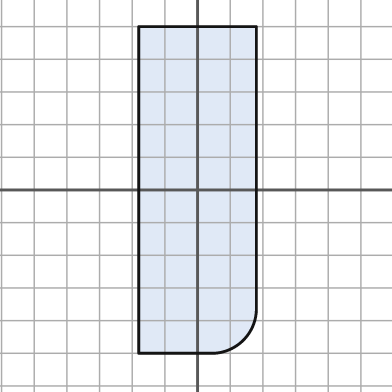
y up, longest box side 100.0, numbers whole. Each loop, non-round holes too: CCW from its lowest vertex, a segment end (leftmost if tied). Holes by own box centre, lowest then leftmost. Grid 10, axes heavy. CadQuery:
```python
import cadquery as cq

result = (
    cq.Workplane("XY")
    .moveTo(-18.0, -50.0)
    .lineTo(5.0, -50.0)
    .threePointArc((14.0, -46.0), (18.0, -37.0))
    .lineTo(18.0, 50.0)
    .lineTo(-18.0, 50.0)
    .close()
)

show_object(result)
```